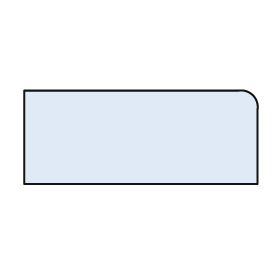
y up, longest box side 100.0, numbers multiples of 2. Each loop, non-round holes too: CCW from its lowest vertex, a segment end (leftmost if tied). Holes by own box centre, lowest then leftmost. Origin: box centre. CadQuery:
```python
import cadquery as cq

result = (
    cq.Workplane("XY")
    .moveTo(-50.0, -20.0)
    .lineTo(50.0, -20.0)
    .lineTo(50.0, 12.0)
    .threePointArc((48.0, 18.0), (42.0, 20.0))
    .lineTo(-50.0, 20.0)
    .close()
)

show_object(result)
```